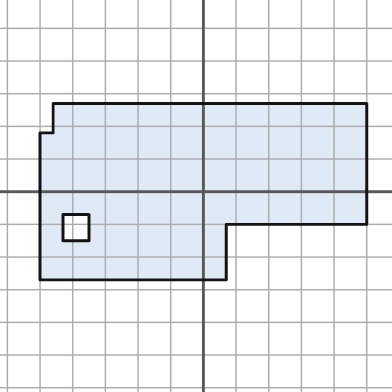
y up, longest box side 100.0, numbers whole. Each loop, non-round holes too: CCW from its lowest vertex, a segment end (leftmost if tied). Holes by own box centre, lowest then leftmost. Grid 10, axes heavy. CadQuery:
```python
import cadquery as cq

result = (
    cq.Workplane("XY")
    .moveTo(-50.0, -27.0)
    .lineTo(7.0, -27.0)
    .lineTo(7.0, -10.0)
    .lineTo(50.0, -10.0)
    .lineTo(50.0, 27.0)
    .lineTo(-46.0, 27.0)
    .lineTo(-46.0, 18.0)
    .lineTo(-50.0, 18.0)
    .close()
    .moveTo(-43.0, -15.0)
    .lineTo(-35.0, -15.0)
    .lineTo(-35.0, -7.0)
    .lineTo(-43.0, -7.0)
    .close()
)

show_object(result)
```